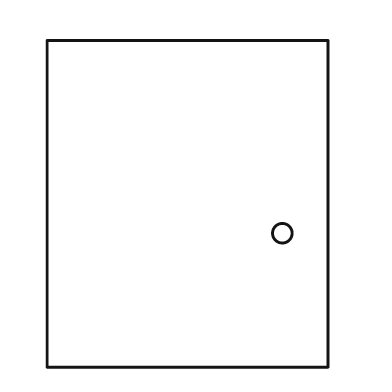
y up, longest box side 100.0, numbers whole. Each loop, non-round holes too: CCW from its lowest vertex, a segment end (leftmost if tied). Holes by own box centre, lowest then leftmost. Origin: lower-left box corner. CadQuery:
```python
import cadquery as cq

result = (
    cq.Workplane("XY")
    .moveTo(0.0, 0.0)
    .lineTo(86.0, 0.0)
    .lineTo(86.0, 100.0)
    .lineTo(0.0, 100.0)
    .close()
    .moveTo(72.0, 41.0)
    .circle(3.0)
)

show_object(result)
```